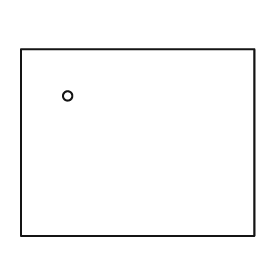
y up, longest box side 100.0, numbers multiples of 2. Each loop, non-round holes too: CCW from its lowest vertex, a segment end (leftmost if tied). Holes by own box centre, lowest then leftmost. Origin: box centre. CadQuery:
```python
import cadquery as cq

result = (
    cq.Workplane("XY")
    .moveTo(-50.0, -40.0)
    .lineTo(50.0, -40.0)
    .lineTo(50.0, 40.0)
    .lineTo(-50.0, 40.0)
    .close()
    .moveTo(-30.0, 20.0)
    .circle(2.0)
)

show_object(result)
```